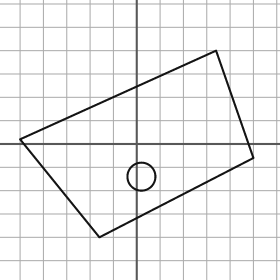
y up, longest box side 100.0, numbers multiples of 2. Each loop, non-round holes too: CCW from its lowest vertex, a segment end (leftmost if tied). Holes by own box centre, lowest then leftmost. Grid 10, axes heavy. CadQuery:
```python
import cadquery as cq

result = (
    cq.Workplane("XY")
    .moveTo(-16.0, -40.0)
    .lineTo(50.0, -6.0)
    .lineTo(34.0, 40.0)
    .lineTo(-50.0, 2.0)
    .close()
    .moveTo(2.0, -14.0)
    .circle(6.0)
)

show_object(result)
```